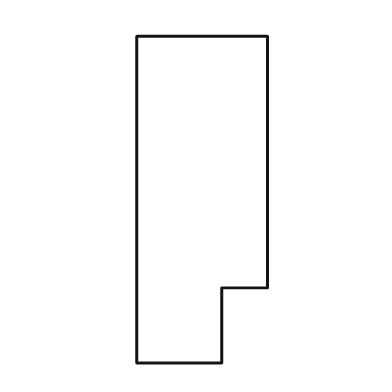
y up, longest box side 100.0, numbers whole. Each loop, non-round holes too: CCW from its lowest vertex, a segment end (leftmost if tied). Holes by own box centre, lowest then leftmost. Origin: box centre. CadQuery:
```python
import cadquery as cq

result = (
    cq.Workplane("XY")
    .moveTo(-20.0, -50.0)
    .lineTo(6.0, -50.0)
    .lineTo(6.0, -27.0)
    .lineTo(20.0, -27.0)
    .lineTo(20.0, 50.0)
    .lineTo(-20.0, 50.0)
    .close()
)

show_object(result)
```